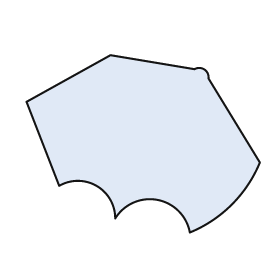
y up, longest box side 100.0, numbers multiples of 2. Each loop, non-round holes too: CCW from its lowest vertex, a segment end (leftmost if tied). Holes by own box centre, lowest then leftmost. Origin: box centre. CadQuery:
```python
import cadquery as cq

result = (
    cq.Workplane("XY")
    .moveTo(20.0, -38.0)
    .threePointArc((38.0, -26.0), (50.0, -8.0))
    .lineTo(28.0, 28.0)
    .threePointArc((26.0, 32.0), (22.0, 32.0))
    .lineTo(-14.0, 38.0)
    .lineTo(-50.0, 18.0)
    .lineTo(-36.0, -18.0)
    .threePointArc((-20.0, -18.0), (-12.0, -32.0))
    .threePointArc((6.0, -24.0), (20.0, -38.0))
    .close()
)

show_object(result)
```